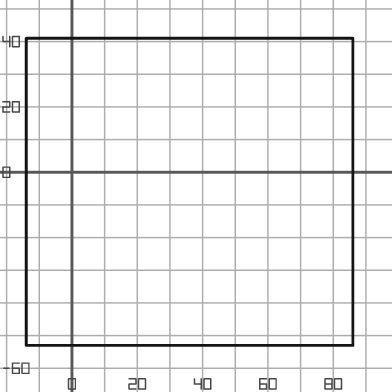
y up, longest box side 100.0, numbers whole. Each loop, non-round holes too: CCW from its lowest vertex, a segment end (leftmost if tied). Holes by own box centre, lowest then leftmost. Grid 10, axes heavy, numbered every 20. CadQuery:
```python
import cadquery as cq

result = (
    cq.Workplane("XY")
    .moveTo(-14.0, -53.0)
    .lineTo(86.0, -53.0)
    .lineTo(86.0, 41.0)
    .lineTo(-14.0, 41.0)
    .close()
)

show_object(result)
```